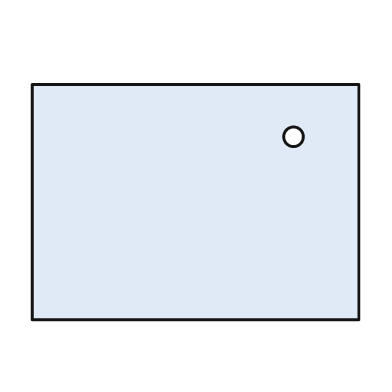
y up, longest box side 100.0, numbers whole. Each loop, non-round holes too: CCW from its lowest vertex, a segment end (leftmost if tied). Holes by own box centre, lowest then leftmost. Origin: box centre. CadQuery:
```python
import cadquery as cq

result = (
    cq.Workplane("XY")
    .moveTo(-50.0, -36.0)
    .lineTo(50.0, -36.0)
    .lineTo(50.0, 36.0)
    .lineTo(-50.0, 36.0)
    .close()
    .moveTo(30.0, 20.0)
    .circle(3.0)
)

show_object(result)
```